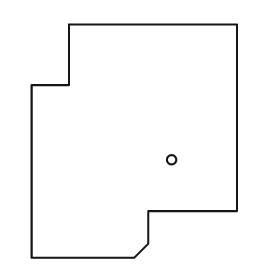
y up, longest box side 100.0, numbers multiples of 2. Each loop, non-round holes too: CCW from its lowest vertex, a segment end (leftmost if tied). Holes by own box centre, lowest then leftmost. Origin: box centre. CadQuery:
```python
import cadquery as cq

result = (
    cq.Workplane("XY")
    .moveTo(-44.0, -50.0)
    .lineTo(0.0, -50.0)
    .lineTo(6.0, -44.0)
    .lineTo(6.0, -30.0)
    .lineTo(44.0, -30.0)
    .lineTo(44.0, 50.0)
    .lineTo(-28.0, 50.0)
    .lineTo(-28.0, 24.0)
    .lineTo(-44.0, 24.0)
    .close()
    .moveTo(16.0, -8.0)
    .circle(2.0)
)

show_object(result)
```